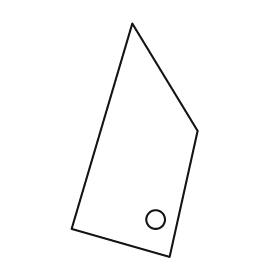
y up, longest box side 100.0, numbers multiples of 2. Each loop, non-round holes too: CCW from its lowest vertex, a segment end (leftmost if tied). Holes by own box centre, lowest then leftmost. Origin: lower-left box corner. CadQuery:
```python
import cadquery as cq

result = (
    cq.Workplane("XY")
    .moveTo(42.0, 0.0)
    .lineTo(54.0, 54.0)
    .lineTo(26.0, 100.0)
    .lineTo(0.0, 12.0)
    .close()
    .moveTo(36.0, 16.0)
    .circle(4.0)
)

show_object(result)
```